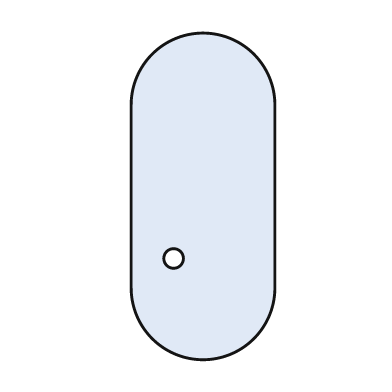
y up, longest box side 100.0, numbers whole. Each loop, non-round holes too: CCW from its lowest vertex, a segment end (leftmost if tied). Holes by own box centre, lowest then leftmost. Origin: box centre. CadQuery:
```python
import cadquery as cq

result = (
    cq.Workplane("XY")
    .moveTo(-22.0, -28.0)
    .threePointArc((0.0, -50.0), (22.0, -28.0))
    .lineTo(22.0, 28.0)
    .threePointArc((0.0, 50.0), (-22.0, 28.0))
    .close()
    .moveTo(-9.0, -19.0)
    .circle(3.0)
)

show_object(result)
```